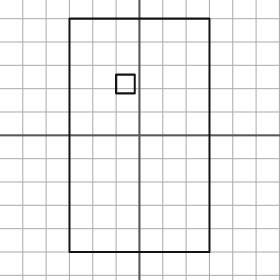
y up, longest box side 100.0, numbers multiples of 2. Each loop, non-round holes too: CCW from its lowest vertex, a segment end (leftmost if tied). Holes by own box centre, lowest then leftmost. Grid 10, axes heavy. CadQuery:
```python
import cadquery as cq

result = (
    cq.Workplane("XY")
    .moveTo(-30.0, -50.0)
    .lineTo(30.0, -50.0)
    .lineTo(30.0, 50.0)
    .lineTo(-30.0, 50.0)
    .close()
    .moveTo(-10.0, 18.0)
    .lineTo(-2.0, 18.0)
    .lineTo(-2.0, 26.0)
    .lineTo(-10.0, 26.0)
    .close()
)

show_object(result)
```